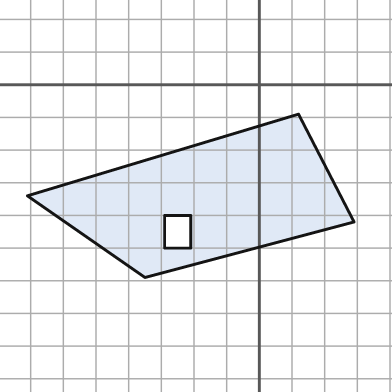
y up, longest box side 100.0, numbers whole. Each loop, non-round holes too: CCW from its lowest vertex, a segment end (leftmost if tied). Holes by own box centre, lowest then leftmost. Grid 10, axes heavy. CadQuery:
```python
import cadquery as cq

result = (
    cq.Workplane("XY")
    .moveTo(-35.0, -59.0)
    .lineTo(29.0, -42.0)
    .lineTo(12.0, -9.0)
    .lineTo(-71.0, -34.0)
    .close()
    .moveTo(-29.0, -50.0)
    .lineTo(-21.0, -50.0)
    .lineTo(-21.0, -40.0)
    .lineTo(-29.0, -40.0)
    .close()
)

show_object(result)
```